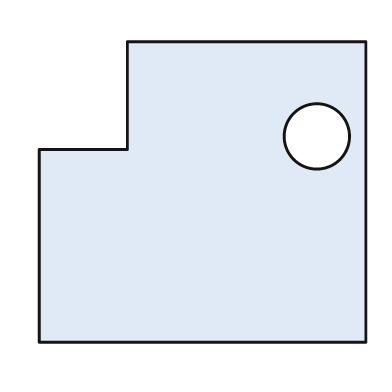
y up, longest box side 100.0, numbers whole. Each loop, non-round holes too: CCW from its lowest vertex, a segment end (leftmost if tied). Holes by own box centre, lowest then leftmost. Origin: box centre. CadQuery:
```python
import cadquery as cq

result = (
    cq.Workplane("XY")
    .moveTo(-50.0, -46.0)
    .lineTo(50.0, -46.0)
    .lineTo(50.0, 46.0)
    .lineTo(-23.0, 46.0)
    .lineTo(-23.0, 13.0)
    .lineTo(-50.0, 13.0)
    .close()
    .moveTo(35.0, 17.0)
    .circle(10.0)
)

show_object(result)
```